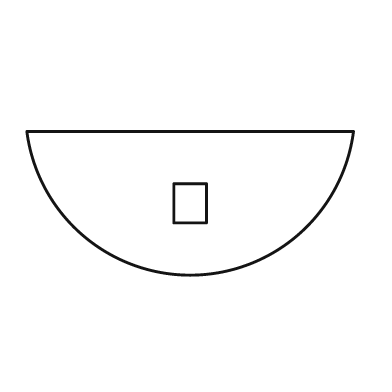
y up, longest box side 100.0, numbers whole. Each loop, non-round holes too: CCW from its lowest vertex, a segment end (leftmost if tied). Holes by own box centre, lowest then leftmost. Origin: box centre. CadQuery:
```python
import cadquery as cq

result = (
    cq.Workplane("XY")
    .moveTo(-50.0, 22.0)
    .threePointArc((0.0, -22.0), (50.0, 22.0))
    .close()
    .moveTo(-5.0, -6.0)
    .lineTo(5.0, -6.0)
    .lineTo(5.0, 6.0)
    .lineTo(-5.0, 6.0)
    .close()
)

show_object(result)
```